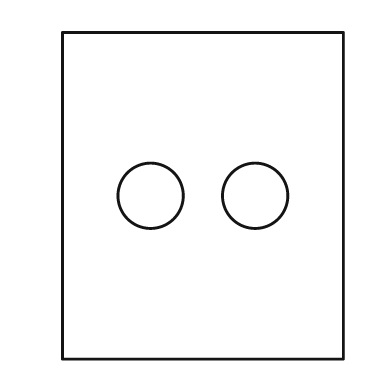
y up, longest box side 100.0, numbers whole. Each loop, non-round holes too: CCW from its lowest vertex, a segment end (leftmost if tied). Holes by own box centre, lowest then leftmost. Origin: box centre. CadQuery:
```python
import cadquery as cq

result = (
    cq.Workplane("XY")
    .moveTo(-43.0, -50.0)
    .lineTo(43.0, -50.0)
    .lineTo(43.0, 50.0)
    .lineTo(-43.0, 50.0)
    .close()
    .moveTo(-16.0, 0.0)
    .circle(10.0)
    .moveTo(16.0, 0.0)
    .circle(10.0)
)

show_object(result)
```